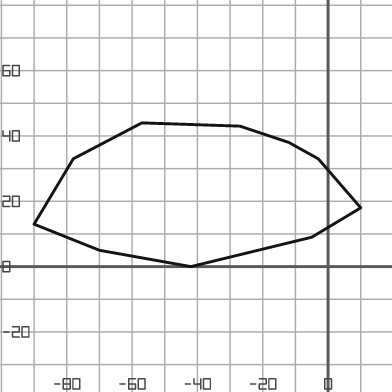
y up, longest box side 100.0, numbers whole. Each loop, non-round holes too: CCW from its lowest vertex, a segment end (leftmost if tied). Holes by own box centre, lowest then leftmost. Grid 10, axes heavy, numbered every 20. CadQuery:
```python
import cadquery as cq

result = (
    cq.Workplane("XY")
    .moveTo(-42.0, 0.0)
    .lineTo(-5.0, 9.0)
    .lineTo(10.0, 18.0)
    .lineTo(-3.0, 33.0)
    .lineTo(-12.0, 38.0)
    .lineTo(-27.0, 43.0)
    .lineTo(-57.0, 44.0)
    .lineTo(-78.0, 33.0)
    .lineTo(-90.0, 13.0)
    .lineTo(-70.0, 5.0)
    .close()
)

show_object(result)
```